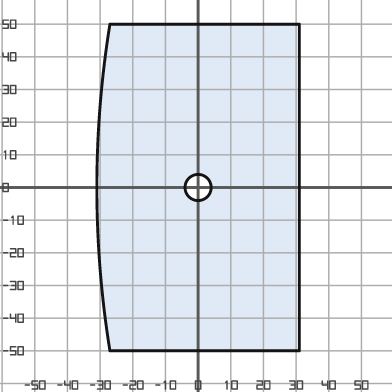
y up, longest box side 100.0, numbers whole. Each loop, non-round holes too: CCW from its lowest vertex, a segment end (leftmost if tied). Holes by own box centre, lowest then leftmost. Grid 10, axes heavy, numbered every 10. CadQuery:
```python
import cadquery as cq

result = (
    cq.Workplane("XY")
    .moveTo(-27.0, -50.0)
    .lineTo(31.0, -50.0)
    .lineTo(31.0, 50.0)
    .lineTo(-27.0, 50.0)
    .threePointArc((-31.0, 0.0), (-27.0, -50.0))
    .close()
    .moveTo(0.0, 0.0)
    .circle(4.0)
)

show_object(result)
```